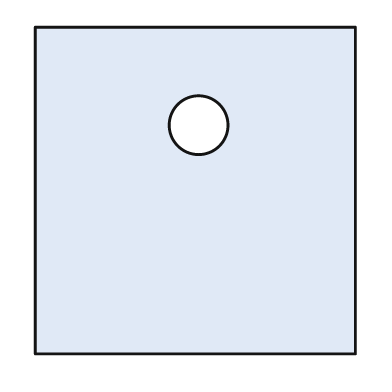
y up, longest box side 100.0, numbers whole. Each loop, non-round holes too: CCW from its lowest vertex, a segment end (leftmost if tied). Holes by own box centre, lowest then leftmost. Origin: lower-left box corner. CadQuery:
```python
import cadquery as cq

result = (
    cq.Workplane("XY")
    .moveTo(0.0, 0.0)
    .lineTo(98.0, 0.0)
    .lineTo(98.0, 100.0)
    .lineTo(0.0, 100.0)
    .close()
    .moveTo(50.0, 70.0)
    .circle(9.0)
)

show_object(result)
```